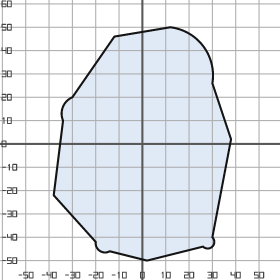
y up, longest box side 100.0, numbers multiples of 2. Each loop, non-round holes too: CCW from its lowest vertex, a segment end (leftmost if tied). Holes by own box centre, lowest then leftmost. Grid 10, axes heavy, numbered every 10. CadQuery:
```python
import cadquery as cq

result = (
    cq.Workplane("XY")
    .moveTo(2.0, -50.0)
    .lineTo(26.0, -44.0)
    .threePointArc((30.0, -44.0), (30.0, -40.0))
    .lineTo(38.0, 2.0)
    .lineTo(30.0, 26.0)
    .threePointArc((26.0, 42.0), (12.0, 50.0))
    .lineTo(-12.0, 46.0)
    .lineTo(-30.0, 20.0)
    .threePointArc((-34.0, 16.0), (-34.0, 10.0))
    .lineTo(-38.0, -22.0)
    .lineTo(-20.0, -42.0)
    .threePointArc((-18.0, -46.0), (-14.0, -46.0))
    .close()
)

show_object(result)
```